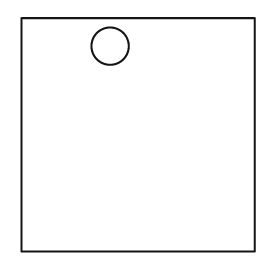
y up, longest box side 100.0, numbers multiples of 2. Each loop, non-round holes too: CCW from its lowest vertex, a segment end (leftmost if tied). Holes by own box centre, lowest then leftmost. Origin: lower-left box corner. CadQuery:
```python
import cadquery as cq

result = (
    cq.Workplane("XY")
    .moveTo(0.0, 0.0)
    .lineTo(100.0, 0.0)
    .lineTo(100.0, 100.0)
    .lineTo(0.0, 100.0)
    .close()
    .moveTo(38.0, 88.0)
    .circle(8.0)
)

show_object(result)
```